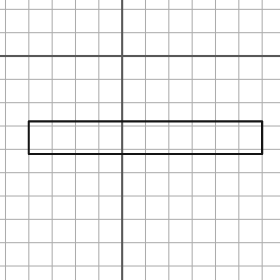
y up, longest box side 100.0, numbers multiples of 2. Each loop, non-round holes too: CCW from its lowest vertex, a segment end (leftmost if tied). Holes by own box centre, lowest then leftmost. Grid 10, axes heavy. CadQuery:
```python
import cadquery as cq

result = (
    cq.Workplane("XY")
    .moveTo(-40.0, -42.0)
    .lineTo(60.0, -42.0)
    .lineTo(60.0, -28.0)
    .lineTo(-40.0, -28.0)
    .close()
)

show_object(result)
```